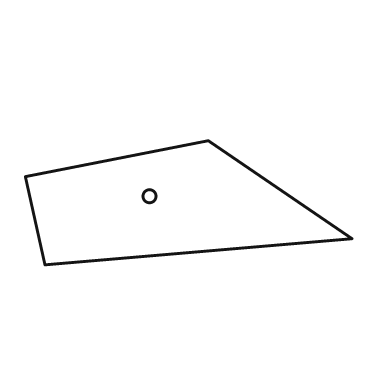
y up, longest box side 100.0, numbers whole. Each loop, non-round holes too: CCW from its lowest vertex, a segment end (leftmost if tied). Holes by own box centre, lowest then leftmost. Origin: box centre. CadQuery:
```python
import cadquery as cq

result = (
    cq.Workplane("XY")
    .moveTo(-44.0, -19.0)
    .lineTo(50.0, -11.0)
    .lineTo(6.0, 19.0)
    .lineTo(-50.0, 8.0)
    .close()
    .moveTo(-12.0, 2.0)
    .circle(2.0)
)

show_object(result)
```